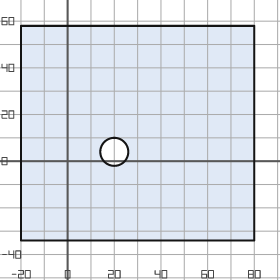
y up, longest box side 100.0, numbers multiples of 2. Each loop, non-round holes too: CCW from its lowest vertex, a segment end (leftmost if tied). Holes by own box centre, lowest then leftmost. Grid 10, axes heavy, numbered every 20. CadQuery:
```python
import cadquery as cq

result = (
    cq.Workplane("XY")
    .moveTo(-20.0, -34.0)
    .lineTo(80.0, -34.0)
    .lineTo(80.0, 58.0)
    .lineTo(-20.0, 58.0)
    .close()
    .moveTo(20.0, 4.0)
    .circle(6.0)
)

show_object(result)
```